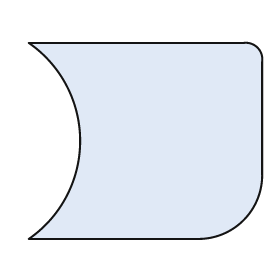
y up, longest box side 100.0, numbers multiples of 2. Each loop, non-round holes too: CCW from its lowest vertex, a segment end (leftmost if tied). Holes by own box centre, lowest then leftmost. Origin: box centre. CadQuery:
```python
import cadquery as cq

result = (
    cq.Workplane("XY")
    .moveTo(-50.0, -42.0)
    .lineTo(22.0, -42.0)
    .threePointArc((42.0, -34.0), (50.0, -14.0))
    .lineTo(50.0, 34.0)
    .threePointArc((48.0, 40.0), (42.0, 42.0))
    .lineTo(-50.0, 42.0)
    .threePointArc((-28.0, 0.0), (-50.0, -42.0))
    .close()
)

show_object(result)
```